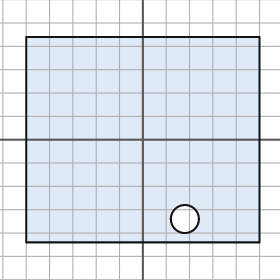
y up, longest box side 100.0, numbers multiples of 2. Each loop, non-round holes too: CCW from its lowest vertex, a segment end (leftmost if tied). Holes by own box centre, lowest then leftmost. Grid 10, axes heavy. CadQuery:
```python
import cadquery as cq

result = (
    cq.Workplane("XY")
    .moveTo(-50.0, -44.0)
    .lineTo(50.0, -44.0)
    .lineTo(50.0, 44.0)
    .lineTo(-50.0, 44.0)
    .close()
    .moveTo(18.0, -34.0)
    .circle(6.0)
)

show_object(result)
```